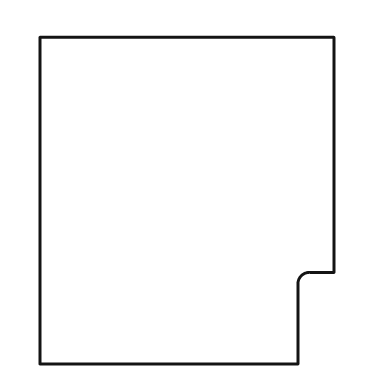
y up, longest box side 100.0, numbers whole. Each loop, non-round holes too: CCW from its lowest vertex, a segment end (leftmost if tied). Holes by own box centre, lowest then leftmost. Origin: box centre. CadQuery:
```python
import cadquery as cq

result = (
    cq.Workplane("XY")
    .moveTo(-45.0, -50.0)
    .lineTo(34.0, -50.0)
    .lineTo(34.0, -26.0)
    .threePointArc((35.0, -23.0), (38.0, -22.0))
    .lineTo(45.0, -22.0)
    .lineTo(45.0, 50.0)
    .lineTo(-45.0, 50.0)
    .close()
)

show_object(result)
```